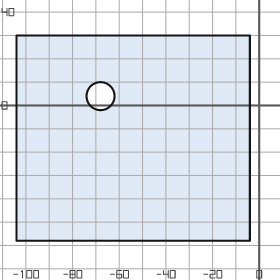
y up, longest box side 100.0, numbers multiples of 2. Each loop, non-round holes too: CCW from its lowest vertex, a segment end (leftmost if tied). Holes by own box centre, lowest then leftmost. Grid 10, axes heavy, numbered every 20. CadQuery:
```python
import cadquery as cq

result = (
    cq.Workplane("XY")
    .moveTo(-104.0, -58.0)
    .lineTo(-4.0, -58.0)
    .lineTo(-4.0, 30.0)
    .lineTo(-104.0, 30.0)
    .close()
    .moveTo(-68.0, 4.0)
    .circle(6.0)
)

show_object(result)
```